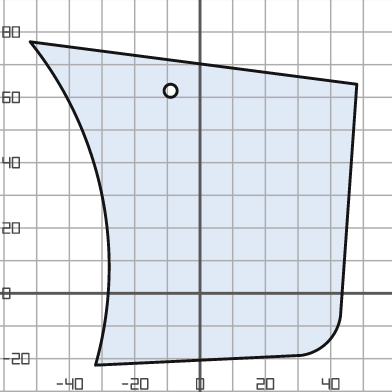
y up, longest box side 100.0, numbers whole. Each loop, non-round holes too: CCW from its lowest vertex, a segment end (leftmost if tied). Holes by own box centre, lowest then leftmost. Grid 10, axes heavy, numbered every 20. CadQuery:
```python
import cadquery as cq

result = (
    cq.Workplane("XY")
    .moveTo(-32.0, -22.0)
    .lineTo(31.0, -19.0)
    .threePointArc((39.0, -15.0), (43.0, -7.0))
    .lineTo(48.0, 64.0)
    .lineTo(-52.0, 77.0)
    .threePointArc((-30.0, 30.0), (-32.0, -22.0))
    .close()
    .moveTo(-9.0, 62.0)
    .circle(2.0)
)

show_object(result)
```